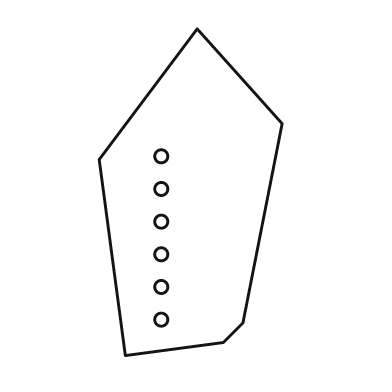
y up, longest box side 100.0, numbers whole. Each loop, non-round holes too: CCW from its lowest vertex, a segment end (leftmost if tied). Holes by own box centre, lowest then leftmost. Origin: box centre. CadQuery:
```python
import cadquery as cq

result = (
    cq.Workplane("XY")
    .moveTo(-20.0, -50.0)
    .lineTo(10.0, -46.0)
    .lineTo(16.0, -40.0)
    .lineTo(28.0, 21.0)
    .lineTo(2.0, 50.0)
    .lineTo(-28.0, 10.0)
    .close()
    .moveTo(-9.0, -39.0)
    .circle(2.0)
    .moveTo(-9.0, -29.0)
    .circle(2.0)
    .moveTo(-9.0, -19.0)
    .circle(2.0)
    .moveTo(-9.0, -9.0)
    .circle(2.0)
    .moveTo(-9.0, 1.0)
    .circle(2.0)
    .moveTo(-9.0, 11.0)
    .circle(2.0)
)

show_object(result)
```